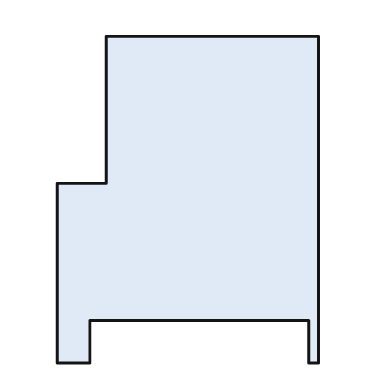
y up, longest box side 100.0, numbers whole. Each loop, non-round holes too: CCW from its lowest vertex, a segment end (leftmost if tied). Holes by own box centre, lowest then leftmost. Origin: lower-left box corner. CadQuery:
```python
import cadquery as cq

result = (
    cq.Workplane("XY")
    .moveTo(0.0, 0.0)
    .lineTo(10.0, 0.0)
    .lineTo(10.0, 13.0)
    .lineTo(77.0, 13.0)
    .lineTo(77.0, 0.0)
    .lineTo(80.0, 0.0)
    .lineTo(80.0, 100.0)
    .lineTo(15.0, 100.0)
    .lineTo(15.0, 55.0)
    .lineTo(0.0, 55.0)
    .close()
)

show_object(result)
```